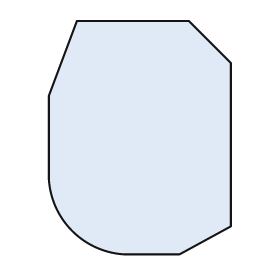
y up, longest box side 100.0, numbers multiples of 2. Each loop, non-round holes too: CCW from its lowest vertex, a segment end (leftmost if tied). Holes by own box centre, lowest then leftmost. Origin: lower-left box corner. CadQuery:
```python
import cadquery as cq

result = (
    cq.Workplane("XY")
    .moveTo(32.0, 0.0)
    .lineTo(56.0, 0.0)
    .lineTo(78.0, 12.0)
    .lineTo(78.0, 82.0)
    .lineTo(60.0, 100.0)
    .lineTo(12.0, 100.0)
    .lineTo(0.0, 68.0)
    .lineTo(0.0, 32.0)
    .threePointArc((10.0, 10.0), (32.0, 0.0))
    .close()
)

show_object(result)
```